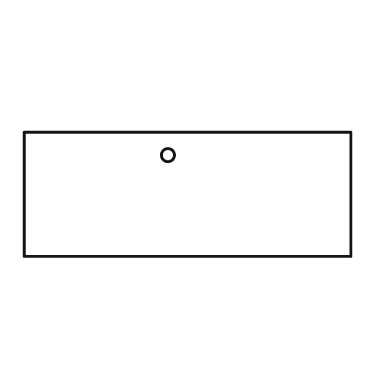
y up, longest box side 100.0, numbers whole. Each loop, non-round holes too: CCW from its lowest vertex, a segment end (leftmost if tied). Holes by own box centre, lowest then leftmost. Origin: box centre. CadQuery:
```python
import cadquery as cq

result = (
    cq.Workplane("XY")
    .moveTo(-50.0, -19.0)
    .lineTo(50.0, -19.0)
    .lineTo(50.0, 19.0)
    .lineTo(-50.0, 19.0)
    .close()
    .moveTo(-6.0, 12.0)
    .circle(2.0)
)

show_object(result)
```